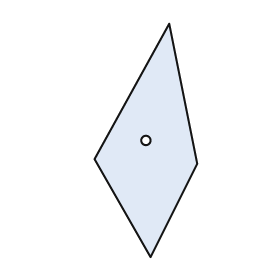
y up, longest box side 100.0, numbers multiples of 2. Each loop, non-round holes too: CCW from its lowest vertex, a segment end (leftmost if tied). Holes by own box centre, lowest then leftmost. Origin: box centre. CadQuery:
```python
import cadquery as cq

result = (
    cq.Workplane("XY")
    .moveTo(2.0, -50.0)
    .lineTo(22.0, -10.0)
    .lineTo(10.0, 50.0)
    .lineTo(-22.0, -8.0)
    .close()
    .moveTo(0.0, 0.0)
    .circle(2.0)
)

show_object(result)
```